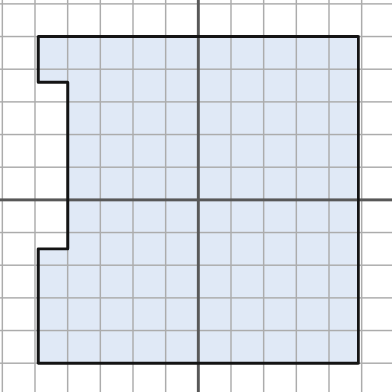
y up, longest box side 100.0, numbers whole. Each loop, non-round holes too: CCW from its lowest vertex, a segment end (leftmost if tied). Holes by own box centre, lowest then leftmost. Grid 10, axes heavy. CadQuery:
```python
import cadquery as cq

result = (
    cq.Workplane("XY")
    .moveTo(-49.0, -50.0)
    .lineTo(49.0, -50.0)
    .lineTo(49.0, 50.0)
    .lineTo(-49.0, 50.0)
    .lineTo(-49.0, 36.0)
    .lineTo(-40.0, 36.0)
    .lineTo(-40.0, -15.0)
    .lineTo(-49.0, -15.0)
    .close()
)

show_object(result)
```